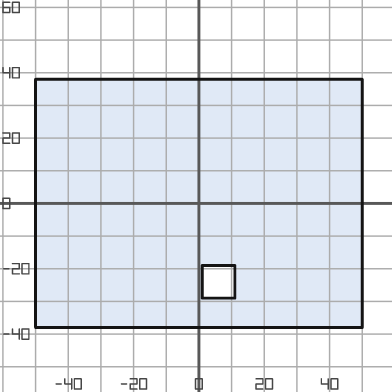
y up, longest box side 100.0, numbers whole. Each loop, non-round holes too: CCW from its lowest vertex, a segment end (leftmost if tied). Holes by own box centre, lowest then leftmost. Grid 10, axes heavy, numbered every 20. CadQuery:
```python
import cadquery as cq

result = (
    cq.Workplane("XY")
    .moveTo(-50.0, -38.0)
    .lineTo(50.0, -38.0)
    .lineTo(50.0, 38.0)
    .lineTo(-50.0, 38.0)
    .close()
    .moveTo(1.0, -29.0)
    .lineTo(11.0, -29.0)
    .lineTo(11.0, -19.0)
    .lineTo(1.0, -19.0)
    .close()
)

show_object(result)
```